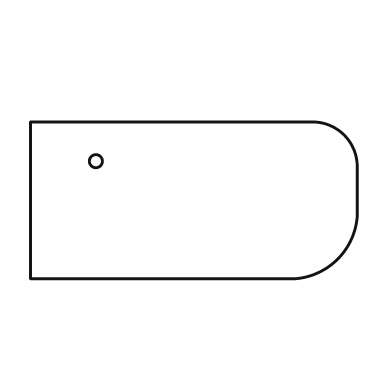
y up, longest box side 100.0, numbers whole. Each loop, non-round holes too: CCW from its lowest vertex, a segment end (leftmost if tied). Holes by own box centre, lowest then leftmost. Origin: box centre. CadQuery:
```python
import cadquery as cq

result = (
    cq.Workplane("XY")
    .moveTo(-50.0, -24.0)
    .lineTo(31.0, -24.0)
    .threePointArc((44.0, -18.0), (50.0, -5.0))
    .lineTo(50.0, 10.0)
    .threePointArc((46.0, 20.0), (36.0, 24.0))
    .lineTo(-50.0, 24.0)
    .close()
    .moveTo(-30.0, 12.0)
    .circle(2.0)
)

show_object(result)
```